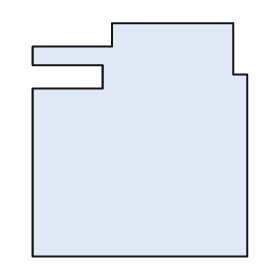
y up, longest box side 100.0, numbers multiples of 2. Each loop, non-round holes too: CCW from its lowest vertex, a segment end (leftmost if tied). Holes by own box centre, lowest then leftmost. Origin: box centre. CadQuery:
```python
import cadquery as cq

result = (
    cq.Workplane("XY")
    .moveTo(-46.0, -50.0)
    .lineTo(46.0, -50.0)
    .lineTo(46.0, 28.0)
    .lineTo(40.0, 28.0)
    .lineTo(40.0, 50.0)
    .lineTo(-12.0, 50.0)
    .lineTo(-12.0, 40.0)
    .lineTo(-46.0, 40.0)
    .lineTo(-46.0, 32.0)
    .lineTo(-16.0, 32.0)
    .lineTo(-16.0, 22.0)
    .lineTo(-46.0, 22.0)
    .close()
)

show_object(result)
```